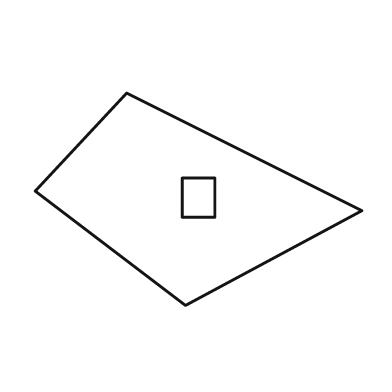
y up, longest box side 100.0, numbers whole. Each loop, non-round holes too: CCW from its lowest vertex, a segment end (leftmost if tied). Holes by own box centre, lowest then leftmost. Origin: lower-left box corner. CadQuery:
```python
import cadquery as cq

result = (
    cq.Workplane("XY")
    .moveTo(46.0, 0.0)
    .lineTo(100.0, 29.0)
    .lineTo(28.0, 65.0)
    .lineTo(0.0, 35.0)
    .close()
    .moveTo(45.0, 27.0)
    .lineTo(55.0, 27.0)
    .lineTo(55.0, 39.0)
    .lineTo(45.0, 39.0)
    .close()
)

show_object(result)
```